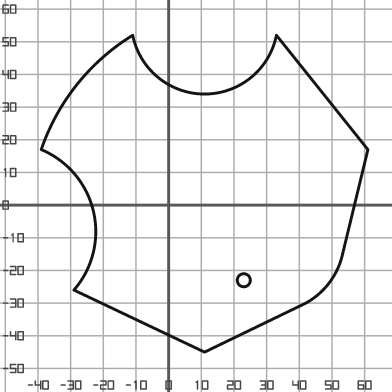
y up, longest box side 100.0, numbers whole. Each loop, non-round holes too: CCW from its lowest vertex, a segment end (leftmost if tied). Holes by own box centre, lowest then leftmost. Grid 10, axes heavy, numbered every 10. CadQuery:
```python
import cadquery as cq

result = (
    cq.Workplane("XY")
    .moveTo(11.0, -45.0)
    .lineTo(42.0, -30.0)
    .threePointArc((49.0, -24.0), (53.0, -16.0))
    .lineTo(61.0, 17.0)
    .lineTo(33.0, 52.0)
    .threePointArc((11.0, 34.0), (-11.0, 52.0))
    .threePointArc((-28.0, 37.0), (-39.0, 17.0))
    .threePointArc((-23.0, -2.0), (-29.0, -26.0))
    .close()
    .moveTo(23.0, -23.0)
    .circle(2.0)
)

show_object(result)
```